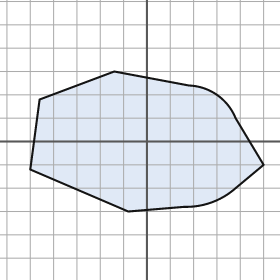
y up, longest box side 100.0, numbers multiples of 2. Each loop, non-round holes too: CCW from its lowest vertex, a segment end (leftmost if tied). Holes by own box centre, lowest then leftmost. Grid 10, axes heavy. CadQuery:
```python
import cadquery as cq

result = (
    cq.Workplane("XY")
    .moveTo(-8.0, -30.0)
    .lineTo(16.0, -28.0)
    .threePointArc((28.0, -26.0), (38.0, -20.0))
    .lineTo(50.0, -10.0)
    .lineTo(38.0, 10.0)
    .threePointArc((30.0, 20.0), (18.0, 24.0))
    .lineTo(-14.0, 30.0)
    .lineTo(-46.0, 18.0)
    .lineTo(-50.0, -12.0)
    .close()
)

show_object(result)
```